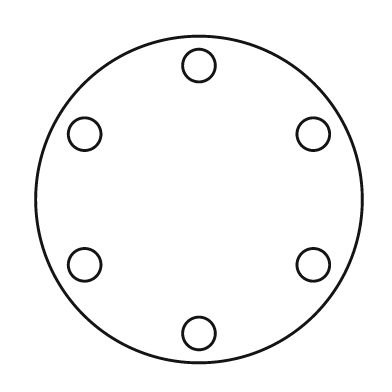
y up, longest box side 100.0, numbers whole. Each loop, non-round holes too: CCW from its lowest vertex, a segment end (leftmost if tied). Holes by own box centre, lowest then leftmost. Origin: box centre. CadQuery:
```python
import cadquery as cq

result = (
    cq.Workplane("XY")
    .moveTo(0.0, 0.0)
    .circle(50.0)
    .moveTo(0.0, -41.0)
    .circle(5.0)
    .moveTo(-35.0, -20.0)
    .circle(5.0)
    .moveTo(35.0, -20.0)
    .circle(5.0)
    .moveTo(-35.0, 20.0)
    .circle(5.0)
    .moveTo(35.0, 20.0)
    .circle(5.0)
    .moveTo(0.0, 41.0)
    .circle(5.0)
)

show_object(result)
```